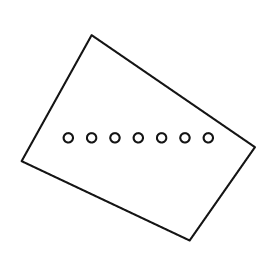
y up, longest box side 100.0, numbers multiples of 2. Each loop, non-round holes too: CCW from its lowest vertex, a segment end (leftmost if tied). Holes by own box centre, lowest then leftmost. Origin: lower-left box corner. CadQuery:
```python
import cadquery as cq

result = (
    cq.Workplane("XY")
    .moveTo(72.0, 0.0)
    .lineTo(100.0, 40.0)
    .lineTo(30.0, 88.0)
    .lineTo(0.0, 34.0)
    .close()
    .moveTo(20.0, 44.0)
    .circle(2.0)
    .moveTo(30.0, 44.0)
    .circle(2.0)
    .moveTo(40.0, 44.0)
    .circle(2.0)
    .moveTo(50.0, 44.0)
    .circle(2.0)
    .moveTo(60.0, 44.0)
    .circle(2.0)
    .moveTo(70.0, 44.0)
    .circle(2.0)
    .moveTo(80.0, 44.0)
    .circle(2.0)
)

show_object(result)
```